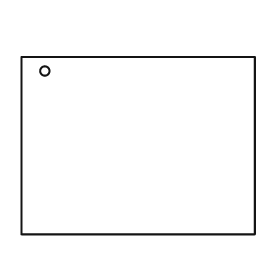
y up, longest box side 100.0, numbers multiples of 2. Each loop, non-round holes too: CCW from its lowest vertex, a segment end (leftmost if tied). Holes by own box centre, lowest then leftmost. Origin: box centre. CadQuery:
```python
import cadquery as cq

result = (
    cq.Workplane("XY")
    .moveTo(-50.0, -38.0)
    .lineTo(50.0, -38.0)
    .lineTo(50.0, 38.0)
    .lineTo(-50.0, 38.0)
    .close()
    .moveTo(-40.0, 32.0)
    .circle(2.0)
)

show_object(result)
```